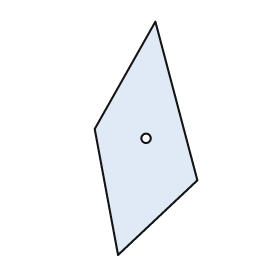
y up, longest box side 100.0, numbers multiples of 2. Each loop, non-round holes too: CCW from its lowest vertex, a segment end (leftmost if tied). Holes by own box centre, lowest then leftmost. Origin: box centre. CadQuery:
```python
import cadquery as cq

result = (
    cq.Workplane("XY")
    .moveTo(-12.0, -50.0)
    .lineTo(22.0, -18.0)
    .lineTo(4.0, 50.0)
    .lineTo(-22.0, 4.0)
    .close()
    .moveTo(0.0, 0.0)
    .circle(2.0)
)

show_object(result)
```